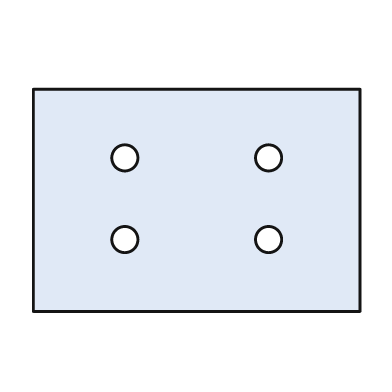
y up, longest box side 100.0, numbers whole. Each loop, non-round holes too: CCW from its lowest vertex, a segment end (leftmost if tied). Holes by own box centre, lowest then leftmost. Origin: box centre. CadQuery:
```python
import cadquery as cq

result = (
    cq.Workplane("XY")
    .moveTo(-50.0, -34.0)
    .lineTo(50.0, -34.0)
    .lineTo(50.0, 34.0)
    .lineTo(-50.0, 34.0)
    .close()
    .moveTo(-22.0, -12.0)
    .circle(4.0)
    .moveTo(22.0, -12.0)
    .circle(4.0)
    .moveTo(-22.0, 13.0)
    .circle(4.0)
    .moveTo(22.0, 13.0)
    .circle(4.0)
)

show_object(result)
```